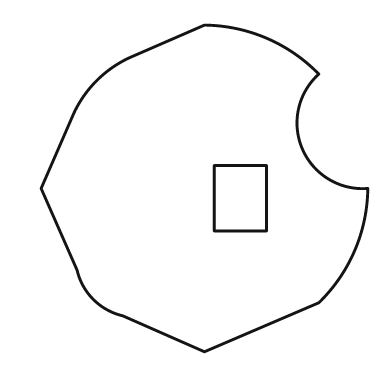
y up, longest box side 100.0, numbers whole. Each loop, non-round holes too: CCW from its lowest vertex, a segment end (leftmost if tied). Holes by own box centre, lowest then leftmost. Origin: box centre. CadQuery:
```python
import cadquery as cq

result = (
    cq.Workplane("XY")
    .moveTo(0.0, -50.0)
    .lineTo(35.0, -35.0)
    .threePointArc((46.0, -19.0), (50.0, 0.0))
    .threePointArc((30.0, 12.0), (35.0, 35.0))
    .threePointArc((19.0, 46.0), (0.0, 50.0))
    .lineTo(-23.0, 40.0)
    .threePointArc((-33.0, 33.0), (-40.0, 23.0))
    .lineTo(-50.0, 0.0)
    .lineTo(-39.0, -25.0)
    .threePointArc((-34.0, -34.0), (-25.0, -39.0))
    .close()
    .moveTo(3.0, -13.0)
    .lineTo(19.0, -13.0)
    .lineTo(19.0, 7.0)
    .lineTo(3.0, 7.0)
    .close()
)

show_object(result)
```